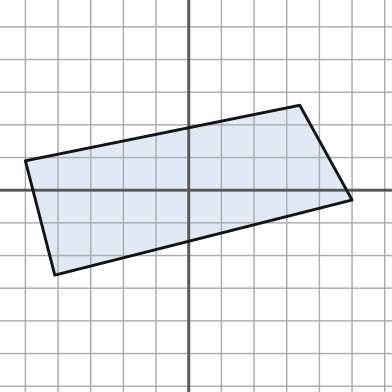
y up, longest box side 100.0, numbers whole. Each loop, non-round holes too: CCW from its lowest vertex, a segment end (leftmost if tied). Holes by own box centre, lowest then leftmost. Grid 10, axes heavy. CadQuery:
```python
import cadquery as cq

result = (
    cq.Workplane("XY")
    .moveTo(-41.0, -26.0)
    .lineTo(50.0, -3.0)
    .lineTo(34.0, 26.0)
    .lineTo(-50.0, 9.0)
    .close()
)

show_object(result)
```